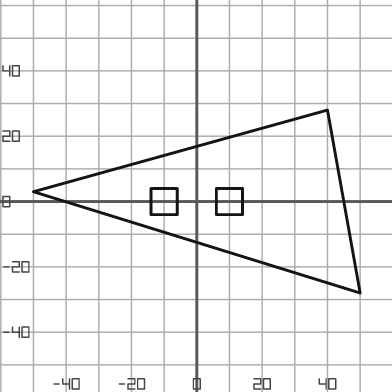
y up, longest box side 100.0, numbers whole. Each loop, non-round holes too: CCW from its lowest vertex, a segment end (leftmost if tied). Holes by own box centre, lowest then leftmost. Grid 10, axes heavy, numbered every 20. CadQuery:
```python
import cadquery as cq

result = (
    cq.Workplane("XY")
    .moveTo(50.0, -28.0)
    .lineTo(40.0, 28.0)
    .lineTo(-50.0, 3.0)
    .close()
    .moveTo(-14.0, -4.0)
    .lineTo(-6.0, -4.0)
    .lineTo(-6.0, 4.0)
    .lineTo(-14.0, 4.0)
    .close()
    .moveTo(6.0, -4.0)
    .lineTo(14.0, -4.0)
    .lineTo(14.0, 4.0)
    .lineTo(6.0, 4.0)
    .close()
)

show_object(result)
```